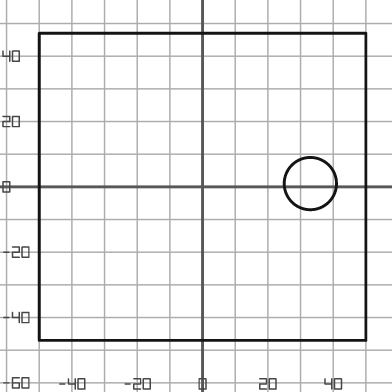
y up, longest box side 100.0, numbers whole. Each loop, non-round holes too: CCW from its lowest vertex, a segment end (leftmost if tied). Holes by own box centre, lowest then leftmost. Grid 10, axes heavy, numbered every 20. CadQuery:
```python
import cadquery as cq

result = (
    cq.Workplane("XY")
    .moveTo(-50.0, -47.0)
    .lineTo(50.0, -47.0)
    .lineTo(50.0, 47.0)
    .lineTo(-50.0, 47.0)
    .close()
    .moveTo(33.0, 1.0)
    .circle(8.0)
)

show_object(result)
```